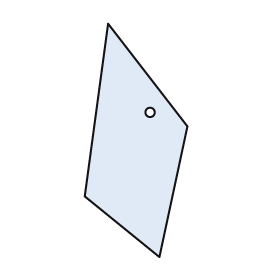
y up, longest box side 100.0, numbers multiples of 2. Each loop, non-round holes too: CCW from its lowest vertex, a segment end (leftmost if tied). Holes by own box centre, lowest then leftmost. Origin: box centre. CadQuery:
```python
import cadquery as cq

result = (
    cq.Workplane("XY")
    .moveTo(10.0, -50.0)
    .lineTo(22.0, 6.0)
    .lineTo(-12.0, 50.0)
    .lineTo(-22.0, -24.0)
    .close()
    .moveTo(6.0, 12.0)
    .circle(2.0)
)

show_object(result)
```